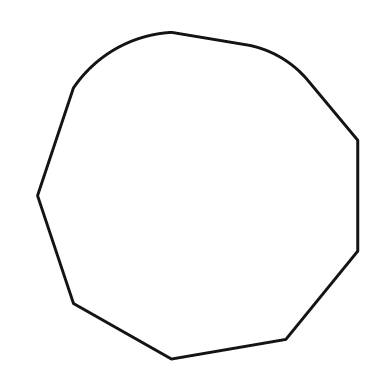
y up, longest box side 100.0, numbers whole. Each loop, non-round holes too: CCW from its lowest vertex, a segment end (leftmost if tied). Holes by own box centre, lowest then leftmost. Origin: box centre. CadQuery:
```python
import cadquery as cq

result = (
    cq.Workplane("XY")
    .moveTo(-8.0, -50.0)
    .lineTo(27.0, -44.0)
    .lineTo(49.0, -17.0)
    .lineTo(49.0, 17.0)
    .lineTo(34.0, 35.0)
    .threePointArc((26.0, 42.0), (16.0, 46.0))
    .lineTo(-8.0, 50.0)
    .threePointArc((-25.0, 45.0), (-38.0, 33.0))
    .lineTo(-49.0, 0.0)
    .lineTo(-38.0, -33.0)
    .close()
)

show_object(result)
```